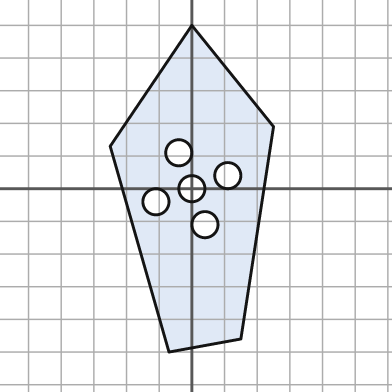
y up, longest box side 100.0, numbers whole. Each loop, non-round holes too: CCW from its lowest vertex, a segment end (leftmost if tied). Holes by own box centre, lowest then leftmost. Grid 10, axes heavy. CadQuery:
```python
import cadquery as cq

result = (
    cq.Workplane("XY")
    .moveTo(-7.0, -50.0)
    .lineTo(15.0, -46.0)
    .lineTo(25.0, 19.0)
    .lineTo(0.0, 50.0)
    .lineTo(-25.0, 13.0)
    .close()
    .moveTo(4.0, -11.0)
    .circle(4.0)
    .moveTo(-11.0, -4.0)
    .circle(4.0)
    .moveTo(0.0, 0.0)
    .circle(4.0)
    .moveTo(11.0, 4.0)
    .circle(4.0)
    .moveTo(-4.0, 11.0)
    .circle(4.0)
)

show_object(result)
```